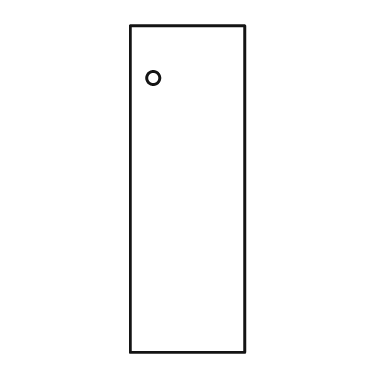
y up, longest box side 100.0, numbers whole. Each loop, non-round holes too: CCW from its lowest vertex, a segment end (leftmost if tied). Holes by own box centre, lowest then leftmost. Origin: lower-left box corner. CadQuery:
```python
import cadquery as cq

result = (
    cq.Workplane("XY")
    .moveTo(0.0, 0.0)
    .lineTo(35.0, 0.0)
    .lineTo(35.0, 100.0)
    .lineTo(0.0, 100.0)
    .close()
    .moveTo(7.0, 84.0)
    .circle(2.0)
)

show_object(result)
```